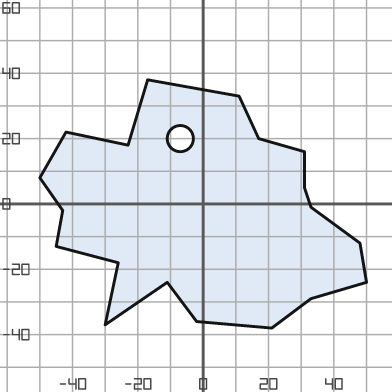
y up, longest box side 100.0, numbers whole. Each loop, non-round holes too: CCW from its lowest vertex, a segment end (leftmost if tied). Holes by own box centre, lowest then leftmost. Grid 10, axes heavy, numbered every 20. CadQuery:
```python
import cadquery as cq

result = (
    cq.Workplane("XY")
    .moveTo(21.0, -38.0)
    .lineTo(33.0, -29.0)
    .lineTo(50.0, -24.0)
    .lineTo(48.0, -12.0)
    .lineTo(33.0, -1.0)
    .lineTo(31.0, 5.0)
    .lineTo(31.0, 16.0)
    .lineTo(17.0, 20.0)
    .lineTo(11.0, 33.0)
    .lineTo(-17.0, 38.0)
    .lineTo(-23.0, 18.0)
    .lineTo(-42.0, 22.0)
    .lineTo(-50.0, 8.0)
    .lineTo(-43.0, -2.0)
    .lineTo(-45.0, -13.0)
    .lineTo(-26.0, -18.0)
    .lineTo(-30.0, -37.0)
    .lineTo(-11.0, -24.0)
    .lineTo(-2.0, -36.0)
    .close()
    .moveTo(-7.0, 20.0)
    .circle(4.0)
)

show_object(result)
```